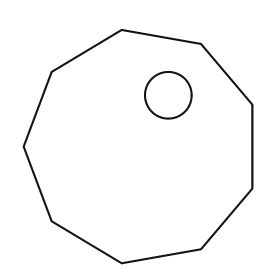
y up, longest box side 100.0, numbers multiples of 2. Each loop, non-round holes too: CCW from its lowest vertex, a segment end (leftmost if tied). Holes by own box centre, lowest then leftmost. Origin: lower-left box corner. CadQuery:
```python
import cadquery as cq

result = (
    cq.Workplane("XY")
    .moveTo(42.0, 0.0)
    .lineTo(76.0, 6.0)
    .lineTo(98.0, 32.0)
    .lineTo(98.0, 68.0)
    .lineTo(76.0, 94.0)
    .lineTo(42.0, 100.0)
    .lineTo(12.0, 82.0)
    .lineTo(0.0, 50.0)
    .lineTo(12.0, 18.0)
    .close()
    .moveTo(62.0, 72.0)
    .circle(10.0)
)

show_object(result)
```